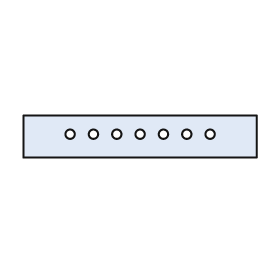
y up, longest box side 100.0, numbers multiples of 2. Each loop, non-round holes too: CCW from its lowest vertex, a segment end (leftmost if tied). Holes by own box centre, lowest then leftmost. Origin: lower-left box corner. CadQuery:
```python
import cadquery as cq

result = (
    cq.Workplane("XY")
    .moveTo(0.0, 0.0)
    .lineTo(100.0, 0.0)
    .lineTo(100.0, 18.0)
    .lineTo(0.0, 18.0)
    .close()
    .moveTo(20.0, 10.0)
    .circle(2.0)
    .moveTo(30.0, 10.0)
    .circle(2.0)
    .moveTo(40.0, 10.0)
    .circle(2.0)
    .moveTo(50.0, 10.0)
    .circle(2.0)
    .moveTo(60.0, 10.0)
    .circle(2.0)
    .moveTo(70.0, 10.0)
    .circle(2.0)
    .moveTo(80.0, 10.0)
    .circle(2.0)
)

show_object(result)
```